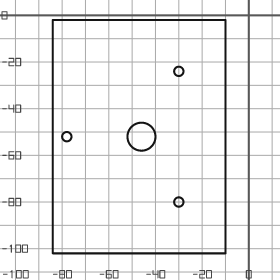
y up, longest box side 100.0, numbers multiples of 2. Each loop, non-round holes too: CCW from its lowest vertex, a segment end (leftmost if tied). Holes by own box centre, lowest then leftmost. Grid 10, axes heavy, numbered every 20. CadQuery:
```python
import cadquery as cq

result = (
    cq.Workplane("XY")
    .moveTo(-84.0, -102.0)
    .lineTo(-10.0, -102.0)
    .lineTo(-10.0, -2.0)
    .lineTo(-84.0, -2.0)
    .close()
    .moveTo(-30.0, -80.0)
    .circle(2.0)
    .moveTo(-78.0, -52.0)
    .circle(2.0)
    .moveTo(-46.0, -52.0)
    .circle(6.0)
    .moveTo(-30.0, -24.0)
    .circle(2.0)
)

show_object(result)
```